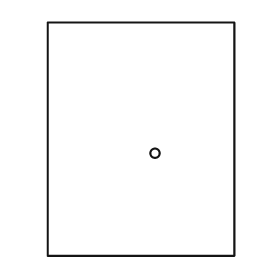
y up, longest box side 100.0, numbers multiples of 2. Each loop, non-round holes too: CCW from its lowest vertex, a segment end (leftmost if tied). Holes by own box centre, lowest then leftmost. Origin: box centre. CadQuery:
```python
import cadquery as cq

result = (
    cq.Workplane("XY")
    .moveTo(-40.0, -50.0)
    .lineTo(40.0, -50.0)
    .lineTo(40.0, 50.0)
    .lineTo(-40.0, 50.0)
    .close()
    .moveTo(6.0, -6.0)
    .circle(2.0)
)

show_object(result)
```